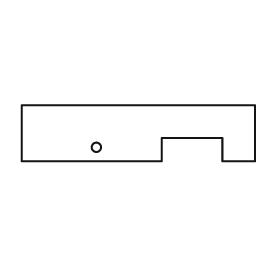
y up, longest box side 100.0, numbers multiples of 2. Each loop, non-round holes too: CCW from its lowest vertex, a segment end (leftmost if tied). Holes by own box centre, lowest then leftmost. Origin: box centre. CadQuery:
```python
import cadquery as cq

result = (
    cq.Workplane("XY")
    .moveTo(-50.0, -12.0)
    .lineTo(10.0, -12.0)
    .lineTo(10.0, -2.0)
    .lineTo(36.0, -2.0)
    .lineTo(36.0, -12.0)
    .lineTo(50.0, -12.0)
    .lineTo(50.0, 12.0)
    .lineTo(-50.0, 12.0)
    .close()
    .moveTo(-18.0, -6.0)
    .circle(2.0)
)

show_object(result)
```